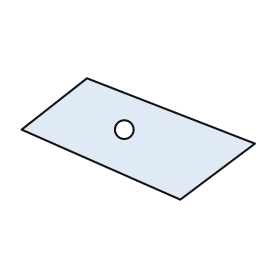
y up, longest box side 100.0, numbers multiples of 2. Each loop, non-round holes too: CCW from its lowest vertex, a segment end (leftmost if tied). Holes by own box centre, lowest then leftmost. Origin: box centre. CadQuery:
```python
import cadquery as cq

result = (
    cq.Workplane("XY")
    .moveTo(18.0, -26.0)
    .lineTo(50.0, -2.0)
    .lineTo(-22.0, 26.0)
    .lineTo(-50.0, 4.0)
    .close()
    .moveTo(-6.0, 4.0)
    .circle(4.0)
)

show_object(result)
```